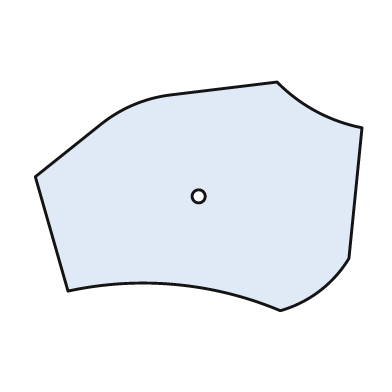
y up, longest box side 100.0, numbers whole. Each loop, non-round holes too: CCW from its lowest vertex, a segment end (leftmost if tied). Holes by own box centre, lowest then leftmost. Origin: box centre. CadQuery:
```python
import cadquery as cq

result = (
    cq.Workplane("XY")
    .moveTo(25.0, -35.0)
    .threePointArc((37.0, -29.0), (46.0, -19.0))
    .lineTo(50.0, 21.0)
    .threePointArc((36.0, 26.0), (24.0, 35.0))
    .lineTo(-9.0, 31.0)
    .threePointArc((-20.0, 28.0), (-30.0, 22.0))
    .lineTo(-50.0, 6.0)
    .lineTo(-40.0, -29.0)
    .threePointArc((-7.0, -27.0), (25.0, -35.0))
    .close()
    .moveTo(0.0, 0.0)
    .circle(2.0)
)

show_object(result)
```